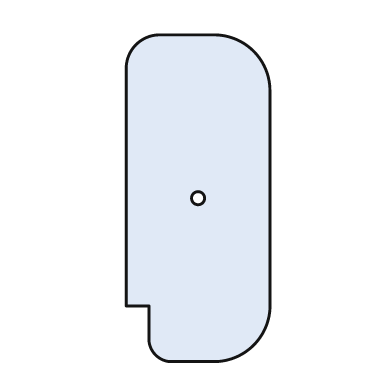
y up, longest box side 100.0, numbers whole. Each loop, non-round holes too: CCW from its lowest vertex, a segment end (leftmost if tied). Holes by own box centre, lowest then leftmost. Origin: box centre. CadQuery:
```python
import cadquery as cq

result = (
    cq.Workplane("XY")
    .moveTo(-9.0, -50.0)
    .lineTo(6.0, -50.0)
    .threePointArc((17.0, -45.0), (22.0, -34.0))
    .lineTo(22.0, 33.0)
    .threePointArc((17.0, 45.0), (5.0, 50.0))
    .lineTo(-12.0, 50.0)
    .threePointArc((-19.0, 47.0), (-22.0, 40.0))
    .lineTo(-22.0, -33.0)
    .lineTo(-15.0, -33.0)
    .lineTo(-15.0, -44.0)
    .threePointArc((-13.0, -48.0), (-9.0, -50.0))
    .close()
    .moveTo(0.0, 0.0)
    .circle(2.0)
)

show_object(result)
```